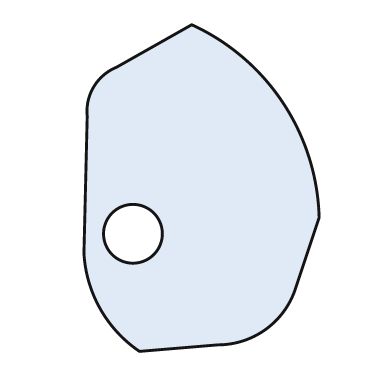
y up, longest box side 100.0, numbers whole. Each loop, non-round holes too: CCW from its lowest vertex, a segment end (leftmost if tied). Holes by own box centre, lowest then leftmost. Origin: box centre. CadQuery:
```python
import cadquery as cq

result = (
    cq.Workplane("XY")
    .moveTo(-19.0, -50.0)
    .lineTo(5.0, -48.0)
    .threePointArc((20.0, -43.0), (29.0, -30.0))
    .lineTo(36.0, -9.0)
    .threePointArc((25.0, 26.0), (-3.0, 50.0))
    .lineTo(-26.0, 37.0)
    .threePointArc((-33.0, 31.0), (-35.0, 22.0))
    .lineTo(-36.0, -20.0)
    .threePointArc((-31.0, -37.0), (-19.0, -50.0))
    .close()
    .moveTo(-21.0, -14.0)
    .circle(9.0)
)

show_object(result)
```